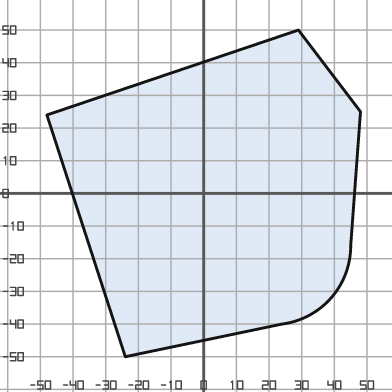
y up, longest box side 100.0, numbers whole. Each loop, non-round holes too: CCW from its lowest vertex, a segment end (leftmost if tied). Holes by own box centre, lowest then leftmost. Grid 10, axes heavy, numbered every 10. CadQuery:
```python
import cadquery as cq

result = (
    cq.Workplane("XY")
    .moveTo(-24.0, -50.0)
    .lineTo(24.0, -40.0)
    .threePointArc((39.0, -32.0), (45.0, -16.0))
    .lineTo(48.0, 25.0)
    .lineTo(29.0, 50.0)
    .lineTo(-48.0, 24.0)
    .close()
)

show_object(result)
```